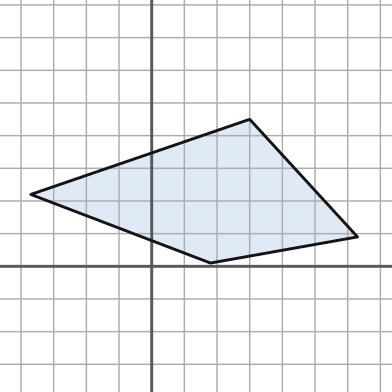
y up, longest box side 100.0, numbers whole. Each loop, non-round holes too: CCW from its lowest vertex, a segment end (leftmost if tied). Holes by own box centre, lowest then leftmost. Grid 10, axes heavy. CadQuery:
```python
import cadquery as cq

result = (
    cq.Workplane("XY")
    .moveTo(18.0, 1.0)
    .lineTo(63.0, 9.0)
    .lineTo(30.0, 45.0)
    .lineTo(-37.0, 22.0)
    .close()
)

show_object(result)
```